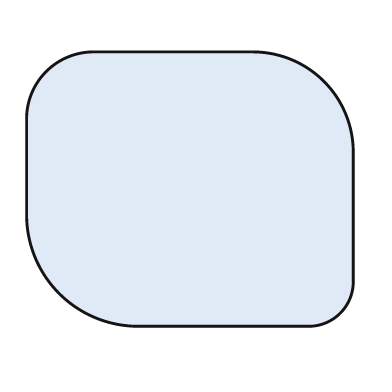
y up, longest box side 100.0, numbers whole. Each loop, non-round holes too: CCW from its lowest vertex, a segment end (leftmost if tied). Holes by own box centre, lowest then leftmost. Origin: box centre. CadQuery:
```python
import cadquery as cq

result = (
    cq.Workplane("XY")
    .moveTo(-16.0, -42.0)
    .lineTo(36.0, -42.0)
    .threePointArc((46.0, -38.0), (50.0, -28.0))
    .lineTo(50.0, 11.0)
    .threePointArc((41.0, 33.0), (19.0, 42.0))
    .lineTo(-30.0, 42.0)
    .threePointArc((-44.0, 36.0), (-50.0, 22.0))
    .lineTo(-50.0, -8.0)
    .threePointArc((-40.0, -32.0), (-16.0, -42.0))
    .close()
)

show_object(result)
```